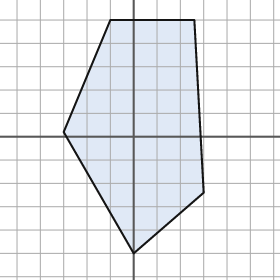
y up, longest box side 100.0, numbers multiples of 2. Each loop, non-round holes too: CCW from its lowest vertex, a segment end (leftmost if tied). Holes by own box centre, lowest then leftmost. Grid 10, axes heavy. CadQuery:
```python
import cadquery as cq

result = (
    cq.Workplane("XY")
    .moveTo(0.0, -50.0)
    .lineTo(30.0, -24.0)
    .lineTo(26.0, 50.0)
    .lineTo(-10.0, 50.0)
    .lineTo(-30.0, 2.0)
    .close()
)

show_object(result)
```